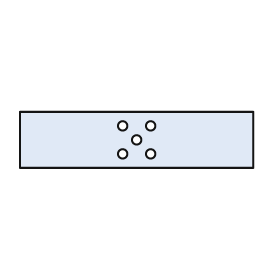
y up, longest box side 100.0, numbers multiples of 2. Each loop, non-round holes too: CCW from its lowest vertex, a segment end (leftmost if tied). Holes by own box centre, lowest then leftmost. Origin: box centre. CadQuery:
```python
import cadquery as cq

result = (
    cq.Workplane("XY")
    .moveTo(-50.0, -12.0)
    .lineTo(50.0, -12.0)
    .lineTo(50.0, 12.0)
    .lineTo(-50.0, 12.0)
    .close()
    .moveTo(-6.0, -6.0)
    .circle(2.0)
    .moveTo(6.0, -6.0)
    .circle(2.0)
    .moveTo(0.0, 0.0)
    .circle(2.0)
    .moveTo(-6.0, 6.0)
    .circle(2.0)
    .moveTo(6.0, 6.0)
    .circle(2.0)
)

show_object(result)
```